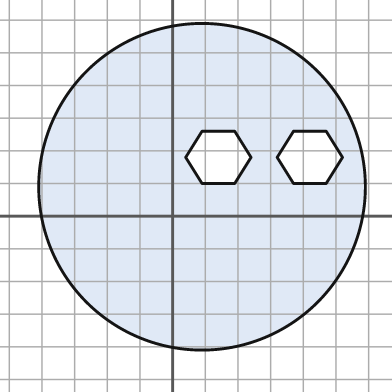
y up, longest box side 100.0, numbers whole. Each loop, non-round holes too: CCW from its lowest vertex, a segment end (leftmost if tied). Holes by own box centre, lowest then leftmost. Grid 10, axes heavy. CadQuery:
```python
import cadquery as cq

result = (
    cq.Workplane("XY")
    .moveTo(9.0, 9.0)
    .circle(50.0)
    .moveTo(9.0, 10.0)
    .lineTo(19.0, 10.0)
    .lineTo(24.0, 18.0)
    .lineTo(19.0, 26.0)
    .lineTo(9.0, 26.0)
    .lineTo(4.0, 18.0)
    .close()
    .moveTo(37.0, 10.0)
    .lineTo(47.0, 10.0)
    .lineTo(52.0, 18.0)
    .lineTo(47.0, 26.0)
    .lineTo(37.0, 26.0)
    .lineTo(32.0, 18.0)
    .close()
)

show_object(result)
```